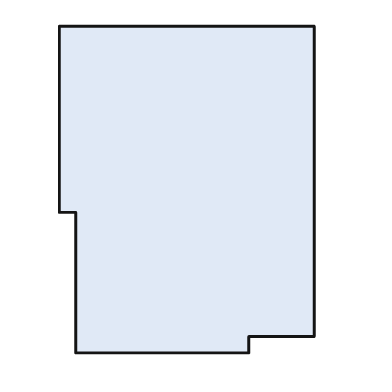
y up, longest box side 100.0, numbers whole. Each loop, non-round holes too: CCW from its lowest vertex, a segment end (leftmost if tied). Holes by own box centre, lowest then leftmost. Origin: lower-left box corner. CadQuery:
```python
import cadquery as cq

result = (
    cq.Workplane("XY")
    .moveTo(5.0, 0.0)
    .lineTo(58.0, 0.0)
    .lineTo(58.0, 5.0)
    .lineTo(78.0, 5.0)
    .lineTo(78.0, 100.0)
    .lineTo(0.0, 100.0)
    .lineTo(0.0, 43.0)
    .lineTo(5.0, 43.0)
    .close()
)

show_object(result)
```